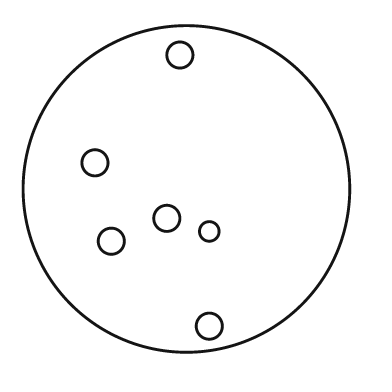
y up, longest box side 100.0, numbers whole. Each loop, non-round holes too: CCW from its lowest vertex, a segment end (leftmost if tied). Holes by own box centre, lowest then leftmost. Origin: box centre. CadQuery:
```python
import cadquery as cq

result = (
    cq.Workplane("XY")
    .moveTo(0.0, 0.0)
    .circle(50.0)
    .moveTo(7.0, -42.0)
    .circle(4.0)
    .moveTo(-23.0, -16.0)
    .circle(4.0)
    .moveTo(7.0, -13.0)
    .circle(3.0)
    .moveTo(-6.0, -9.0)
    .circle(4.0)
    .moveTo(-28.0, 8.0)
    .circle(4.0)
    .moveTo(-2.0, 41.0)
    .circle(4.0)
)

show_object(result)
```